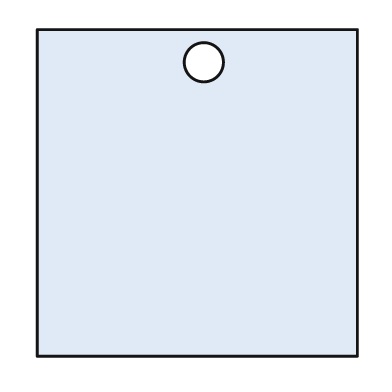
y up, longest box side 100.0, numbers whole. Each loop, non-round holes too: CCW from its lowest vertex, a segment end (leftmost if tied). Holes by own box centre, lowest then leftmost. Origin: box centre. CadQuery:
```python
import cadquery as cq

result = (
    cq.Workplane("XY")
    .moveTo(-49.0, -50.0)
    .lineTo(49.0, -50.0)
    .lineTo(49.0, 50.0)
    .lineTo(-49.0, 50.0)
    .close()
    .moveTo(2.0, 40.0)
    .circle(6.0)
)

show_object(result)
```